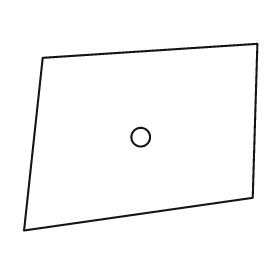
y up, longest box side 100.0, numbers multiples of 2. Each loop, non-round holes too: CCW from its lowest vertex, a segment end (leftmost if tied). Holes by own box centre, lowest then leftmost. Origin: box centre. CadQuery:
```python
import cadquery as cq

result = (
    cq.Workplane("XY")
    .moveTo(-50.0, -40.0)
    .lineTo(48.0, -26.0)
    .lineTo(50.0, 40.0)
    .lineTo(-42.0, 34.0)
    .close()
    .moveTo(0.0, 0.0)
    .circle(4.0)
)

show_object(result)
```